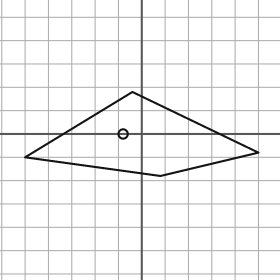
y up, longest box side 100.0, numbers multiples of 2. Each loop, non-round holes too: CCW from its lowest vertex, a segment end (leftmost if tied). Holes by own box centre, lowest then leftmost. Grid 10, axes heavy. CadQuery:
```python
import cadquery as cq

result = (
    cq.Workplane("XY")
    .moveTo(8.0, -18.0)
    .lineTo(50.0, -8.0)
    .lineTo(-4.0, 18.0)
    .lineTo(-50.0, -10.0)
    .close()
    .moveTo(-8.0, 0.0)
    .circle(2.0)
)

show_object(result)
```